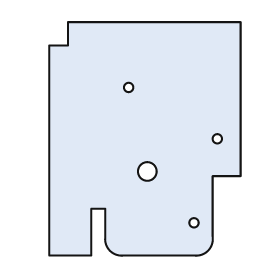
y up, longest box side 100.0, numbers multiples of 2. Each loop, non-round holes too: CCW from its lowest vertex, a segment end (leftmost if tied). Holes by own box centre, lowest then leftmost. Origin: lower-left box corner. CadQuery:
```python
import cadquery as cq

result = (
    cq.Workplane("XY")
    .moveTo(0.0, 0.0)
    .lineTo(18.0, 0.0)
    .lineTo(18.0, 20.0)
    .lineTo(24.0, 20.0)
    .lineTo(24.0, 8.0)
    .threePointArc((26.0, 2.0), (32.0, 0.0))
    .lineTo(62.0, 0.0)
    .threePointArc((68.0, 2.0), (70.0, 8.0))
    .lineTo(70.0, 34.0)
    .lineTo(82.0, 34.0)
    .lineTo(82.0, 100.0)
    .lineTo(8.0, 100.0)
    .lineTo(8.0, 90.0)
    .lineTo(0.0, 90.0)
    .close()
    .moveTo(62.0, 14.0)
    .circle(2.0)
    .moveTo(42.0, 36.0)
    .circle(4.0)
    .moveTo(72.0, 50.0)
    .circle(2.0)
    .moveTo(34.0, 72.0)
    .circle(2.0)
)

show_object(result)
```